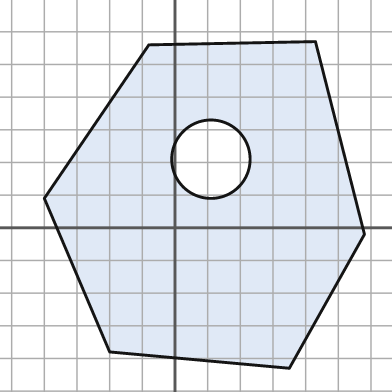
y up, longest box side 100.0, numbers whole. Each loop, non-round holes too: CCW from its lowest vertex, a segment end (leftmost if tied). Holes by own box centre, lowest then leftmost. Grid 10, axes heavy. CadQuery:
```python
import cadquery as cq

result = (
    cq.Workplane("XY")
    .moveTo(35.0, -43.0)
    .lineTo(58.0, -2.0)
    .lineTo(43.0, 57.0)
    .lineTo(-8.0, 56.0)
    .lineTo(-40.0, 9.0)
    .lineTo(-20.0, -38.0)
    .close()
    .moveTo(11.0, 21.0)
    .circle(12.0)
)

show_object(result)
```